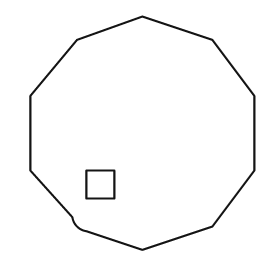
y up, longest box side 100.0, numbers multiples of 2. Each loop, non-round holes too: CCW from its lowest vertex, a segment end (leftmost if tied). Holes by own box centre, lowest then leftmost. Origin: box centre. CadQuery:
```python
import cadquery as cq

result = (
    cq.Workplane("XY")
    .moveTo(0.0, -50.0)
    .lineTo(30.0, -40.0)
    .lineTo(48.0, -16.0)
    .lineTo(48.0, 16.0)
    .lineTo(30.0, 40.0)
    .lineTo(0.0, 50.0)
    .lineTo(-28.0, 40.0)
    .lineTo(-48.0, 16.0)
    .lineTo(-48.0, -16.0)
    .lineTo(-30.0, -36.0)
    .threePointArc((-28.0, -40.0), (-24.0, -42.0))
    .close()
    .moveTo(-24.0, -28.0)
    .lineTo(-12.0, -28.0)
    .lineTo(-12.0, -16.0)
    .lineTo(-24.0, -16.0)
    .close()
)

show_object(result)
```